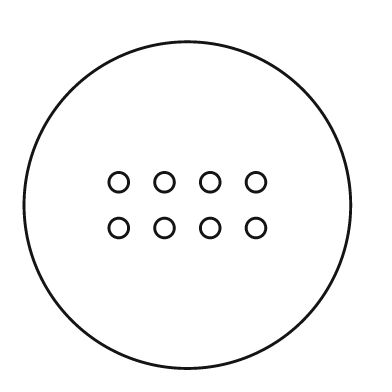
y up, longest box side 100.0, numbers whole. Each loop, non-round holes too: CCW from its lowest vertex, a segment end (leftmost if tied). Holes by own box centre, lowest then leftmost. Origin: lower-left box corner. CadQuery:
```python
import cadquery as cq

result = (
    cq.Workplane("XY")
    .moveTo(50.0, 50.0)
    .circle(50.0)
    .moveTo(29.0, 43.0)
    .circle(3.0)
    .moveTo(43.0, 43.0)
    .circle(3.0)
    .moveTo(57.0, 43.0)
    .circle(3.0)
    .moveTo(71.0, 43.0)
    .circle(3.0)
    .moveTo(29.0, 57.0)
    .circle(3.0)
    .moveTo(43.0, 57.0)
    .circle(3.0)
    .moveTo(57.0, 57.0)
    .circle(3.0)
    .moveTo(71.0, 57.0)
    .circle(3.0)
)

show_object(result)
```